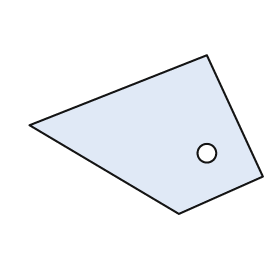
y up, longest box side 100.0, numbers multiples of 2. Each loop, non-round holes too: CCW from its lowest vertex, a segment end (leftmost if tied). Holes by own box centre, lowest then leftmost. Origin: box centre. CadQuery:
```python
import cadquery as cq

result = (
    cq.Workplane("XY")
    .moveTo(14.0, -34.0)
    .lineTo(50.0, -18.0)
    .lineTo(26.0, 34.0)
    .lineTo(-50.0, 4.0)
    .close()
    .moveTo(26.0, -8.0)
    .circle(4.0)
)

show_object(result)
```